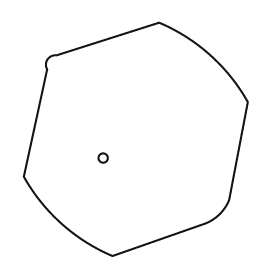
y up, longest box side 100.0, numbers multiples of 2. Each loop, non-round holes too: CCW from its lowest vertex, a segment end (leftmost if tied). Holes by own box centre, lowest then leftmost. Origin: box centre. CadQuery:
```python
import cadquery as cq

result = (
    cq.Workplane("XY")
    .moveTo(-10.0, -50.0)
    .lineTo(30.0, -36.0)
    .threePointArc((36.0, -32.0), (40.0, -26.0))
    .lineTo(48.0, 16.0)
    .threePointArc((32.0, 36.0), (10.0, 50.0))
    .lineTo(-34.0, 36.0)
    .threePointArc((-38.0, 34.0), (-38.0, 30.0))
    .lineTo(-48.0, -16.0)
    .threePointArc((-32.0, -36.0), (-10.0, -50.0))
    .close()
    .moveTo(-14.0, -8.0)
    .circle(2.0)
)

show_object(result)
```